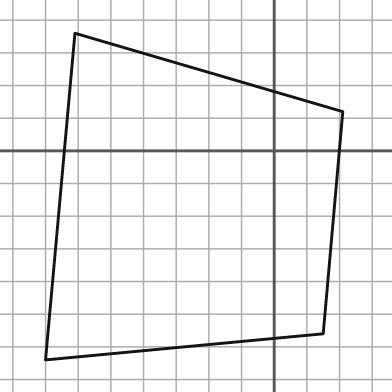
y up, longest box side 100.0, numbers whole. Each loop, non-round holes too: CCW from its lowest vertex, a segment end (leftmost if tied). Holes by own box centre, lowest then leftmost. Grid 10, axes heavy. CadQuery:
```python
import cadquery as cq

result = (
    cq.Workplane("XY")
    .moveTo(-70.0, -64.0)
    .lineTo(15.0, -56.0)
    .lineTo(21.0, 12.0)
    .lineTo(-61.0, 36.0)
    .close()
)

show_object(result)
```